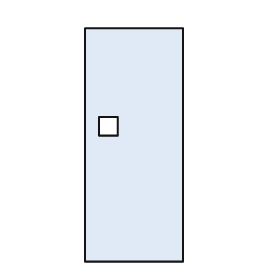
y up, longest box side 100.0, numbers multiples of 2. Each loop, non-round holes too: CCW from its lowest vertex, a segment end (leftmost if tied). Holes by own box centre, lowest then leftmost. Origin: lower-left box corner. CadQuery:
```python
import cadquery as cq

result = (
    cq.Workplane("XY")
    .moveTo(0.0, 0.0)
    .lineTo(42.0, 0.0)
    .lineTo(42.0, 100.0)
    .lineTo(0.0, 100.0)
    .close()
    .moveTo(6.0, 54.0)
    .lineTo(14.0, 54.0)
    .lineTo(14.0, 62.0)
    .lineTo(6.0, 62.0)
    .close()
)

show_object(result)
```